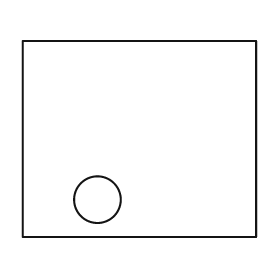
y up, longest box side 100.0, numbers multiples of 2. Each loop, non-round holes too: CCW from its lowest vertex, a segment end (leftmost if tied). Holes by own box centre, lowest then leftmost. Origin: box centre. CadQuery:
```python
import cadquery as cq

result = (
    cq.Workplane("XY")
    .moveTo(-50.0, -42.0)
    .lineTo(50.0, -42.0)
    .lineTo(50.0, 42.0)
    .lineTo(-50.0, 42.0)
    .close()
    .moveTo(-18.0, -26.0)
    .circle(10.0)
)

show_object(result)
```